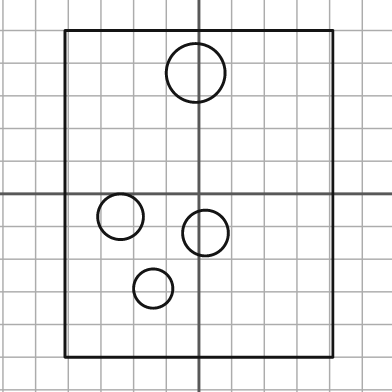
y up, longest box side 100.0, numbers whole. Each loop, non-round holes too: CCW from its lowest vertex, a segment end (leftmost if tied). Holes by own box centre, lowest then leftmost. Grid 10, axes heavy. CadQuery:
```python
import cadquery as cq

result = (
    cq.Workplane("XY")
    .moveTo(-41.0, -50.0)
    .lineTo(41.0, -50.0)
    .lineTo(41.0, 50.0)
    .lineTo(-41.0, 50.0)
    .close()
    .moveTo(-14.0, -29.0)
    .circle(6.0)
    .moveTo(2.0, -12.0)
    .circle(7.0)
    .moveTo(-24.0, -7.0)
    .circle(7.0)
    .moveTo(-1.0, 37.0)
    .circle(9.0)
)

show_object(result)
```